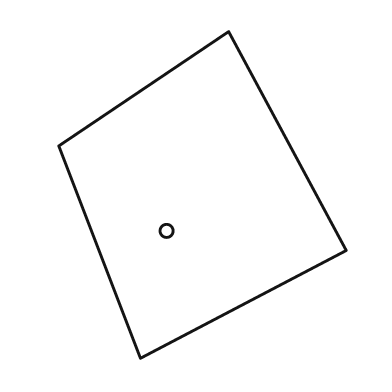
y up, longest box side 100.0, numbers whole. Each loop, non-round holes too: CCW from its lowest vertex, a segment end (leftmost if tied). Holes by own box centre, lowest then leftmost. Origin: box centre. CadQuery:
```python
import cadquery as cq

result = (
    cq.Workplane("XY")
    .moveTo(-19.0, -50.0)
    .lineTo(44.0, -17.0)
    .lineTo(8.0, 50.0)
    .lineTo(-44.0, 15.0)
    .close()
    .moveTo(-11.0, -11.0)
    .circle(2.0)
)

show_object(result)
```